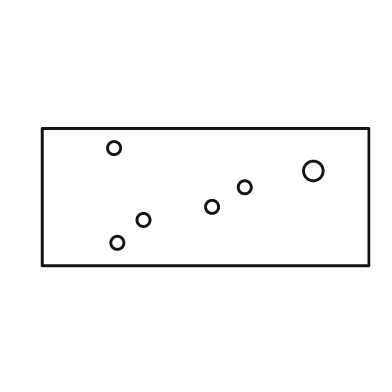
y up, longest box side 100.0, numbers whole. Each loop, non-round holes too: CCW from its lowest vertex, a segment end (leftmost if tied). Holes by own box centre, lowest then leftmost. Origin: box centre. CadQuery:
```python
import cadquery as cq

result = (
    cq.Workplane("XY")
    .moveTo(-50.0, -21.0)
    .lineTo(50.0, -21.0)
    .lineTo(50.0, 21.0)
    .lineTo(-50.0, 21.0)
    .close()
    .moveTo(-27.0, -14.0)
    .circle(2.0)
    .moveTo(-19.0, -7.0)
    .circle(2.0)
    .moveTo(2.0, -3.0)
    .circle(2.0)
    .moveTo(12.0, 3.0)
    .circle(2.0)
    .moveTo(33.0, 8.0)
    .circle(3.0)
    .moveTo(-28.0, 15.0)
    .circle(2.0)
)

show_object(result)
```